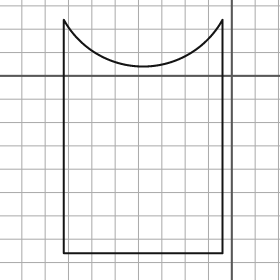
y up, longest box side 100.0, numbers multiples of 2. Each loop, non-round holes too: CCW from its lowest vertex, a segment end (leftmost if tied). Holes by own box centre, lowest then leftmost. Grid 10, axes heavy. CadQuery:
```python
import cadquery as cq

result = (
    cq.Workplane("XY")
    .moveTo(-72.0, -76.0)
    .lineTo(-4.0, -76.0)
    .lineTo(-4.0, 24.0)
    .threePointArc((-38.0, 4.0), (-72.0, 24.0))
    .close()
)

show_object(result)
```